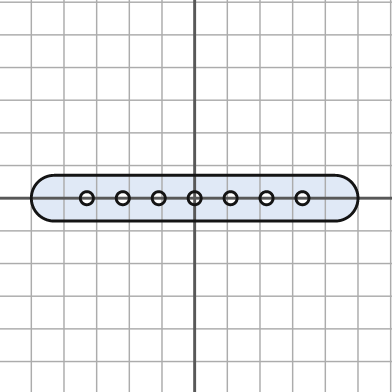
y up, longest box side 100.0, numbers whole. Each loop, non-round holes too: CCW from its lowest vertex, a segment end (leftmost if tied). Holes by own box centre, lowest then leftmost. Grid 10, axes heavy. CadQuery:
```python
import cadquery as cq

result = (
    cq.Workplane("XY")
    .moveTo(-43.0, -7.0)
    .lineTo(43.0, -7.0)
    .threePointArc((50.0, 0.0), (43.0, 7.0))
    .lineTo(-43.0, 7.0)
    .threePointArc((-50.0, 0.0), (-43.0, -7.0))
    .close()
    .moveTo(-33.0, 0.0)
    .circle(2.0)
    .moveTo(-22.0, 0.0)
    .circle(2.0)
    .moveTo(-11.0, 0.0)
    .circle(2.0)
    .moveTo(0.0, 0.0)
    .circle(2.0)
    .moveTo(11.0, 0.0)
    .circle(2.0)
    .moveTo(22.0, 0.0)
    .circle(2.0)
    .moveTo(33.0, 0.0)
    .circle(2.0)
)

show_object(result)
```